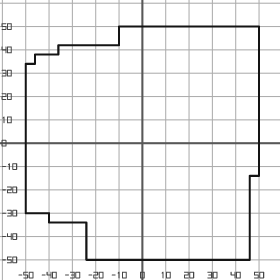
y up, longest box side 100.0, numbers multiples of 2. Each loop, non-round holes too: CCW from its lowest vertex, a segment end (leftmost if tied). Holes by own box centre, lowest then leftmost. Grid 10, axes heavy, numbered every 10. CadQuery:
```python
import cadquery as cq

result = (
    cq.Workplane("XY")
    .moveTo(-24.0, -50.0)
    .lineTo(46.0, -50.0)
    .lineTo(46.0, -14.0)
    .lineTo(50.0, -14.0)
    .lineTo(50.0, 50.0)
    .lineTo(-10.0, 50.0)
    .lineTo(-10.0, 42.0)
    .lineTo(-36.0, 42.0)
    .lineTo(-36.0, 38.0)
    .lineTo(-46.0, 38.0)
    .lineTo(-46.0, 34.0)
    .lineTo(-50.0, 34.0)
    .lineTo(-50.0, -30.0)
    .lineTo(-40.0, -30.0)
    .lineTo(-40.0, -34.0)
    .lineTo(-24.0, -34.0)
    .close()
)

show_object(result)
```